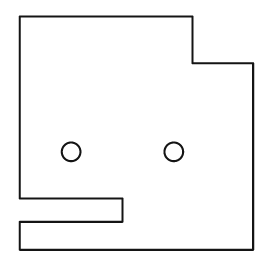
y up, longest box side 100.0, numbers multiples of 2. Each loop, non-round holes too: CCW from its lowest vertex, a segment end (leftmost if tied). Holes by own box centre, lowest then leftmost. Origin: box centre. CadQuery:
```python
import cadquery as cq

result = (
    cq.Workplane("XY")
    .moveTo(-50.0, -50.0)
    .lineTo(50.0, -50.0)
    .lineTo(50.0, 30.0)
    .lineTo(24.0, 30.0)
    .lineTo(24.0, 50.0)
    .lineTo(-50.0, 50.0)
    .lineTo(-50.0, -28.0)
    .lineTo(-6.0, -28.0)
    .lineTo(-6.0, -38.0)
    .lineTo(-50.0, -38.0)
    .close()
    .moveTo(-28.0, -8.0)
    .circle(4.0)
    .moveTo(16.0, -8.0)
    .circle(4.0)
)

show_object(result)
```